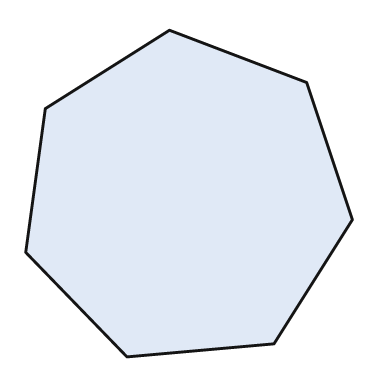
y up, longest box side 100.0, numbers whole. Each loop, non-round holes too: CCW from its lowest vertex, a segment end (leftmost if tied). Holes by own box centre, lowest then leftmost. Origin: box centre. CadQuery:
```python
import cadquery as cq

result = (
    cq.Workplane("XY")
    .moveTo(-19.0, -50.0)
    .lineTo(26.0, -46.0)
    .lineTo(50.0, -8.0)
    .lineTo(36.0, 34.0)
    .lineTo(-6.0, 50.0)
    .lineTo(-44.0, 26.0)
    .lineTo(-50.0, -18.0)
    .close()
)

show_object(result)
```